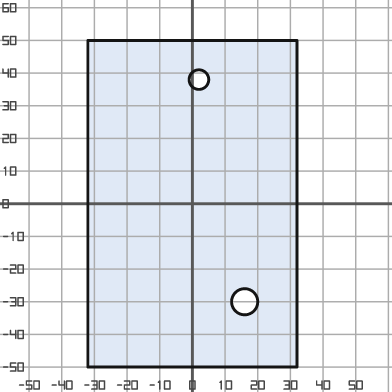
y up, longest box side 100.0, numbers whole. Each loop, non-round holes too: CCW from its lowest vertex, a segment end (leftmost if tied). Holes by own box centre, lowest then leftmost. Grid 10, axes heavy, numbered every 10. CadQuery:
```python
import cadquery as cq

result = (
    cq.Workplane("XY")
    .moveTo(-32.0, -50.0)
    .lineTo(32.0, -50.0)
    .lineTo(32.0, 50.0)
    .lineTo(-32.0, 50.0)
    .close()
    .moveTo(16.0, -30.0)
    .circle(4.0)
    .moveTo(2.0, 38.0)
    .circle(3.0)
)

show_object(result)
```